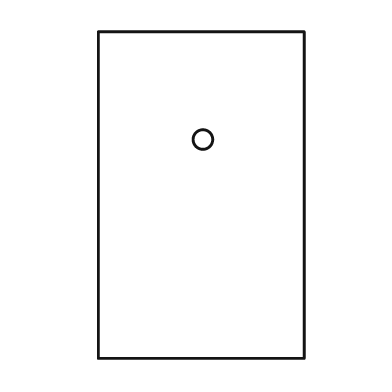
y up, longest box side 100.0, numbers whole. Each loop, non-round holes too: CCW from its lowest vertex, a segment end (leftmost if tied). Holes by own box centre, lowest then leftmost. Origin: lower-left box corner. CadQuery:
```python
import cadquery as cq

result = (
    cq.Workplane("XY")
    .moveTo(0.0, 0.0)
    .lineTo(63.0, 0.0)
    .lineTo(63.0, 100.0)
    .lineTo(0.0, 100.0)
    .close()
    .moveTo(32.0, 67.0)
    .circle(3.0)
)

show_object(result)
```